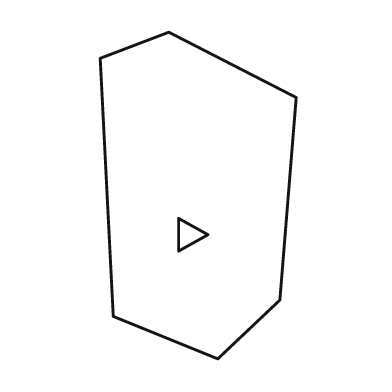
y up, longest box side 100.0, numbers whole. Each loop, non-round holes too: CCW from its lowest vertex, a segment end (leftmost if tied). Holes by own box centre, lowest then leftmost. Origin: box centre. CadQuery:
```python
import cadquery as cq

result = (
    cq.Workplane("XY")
    .moveTo(6.0, -50.0)
    .lineTo(25.0, -32.0)
    .lineTo(30.0, 30.0)
    .lineTo(-9.0, 50.0)
    .lineTo(-30.0, 42.0)
    .lineTo(-26.0, -37.0)
    .close()
    .moveTo(-6.0, -17.0)
    .lineTo(3.0, -12.0)
    .lineTo(-6.0, -7.0)
    .close()
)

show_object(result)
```